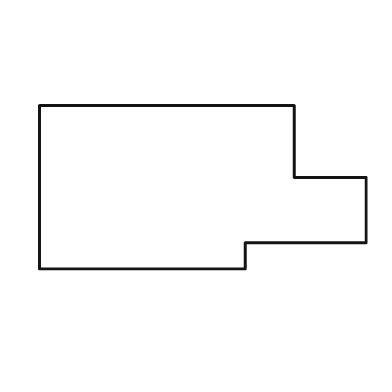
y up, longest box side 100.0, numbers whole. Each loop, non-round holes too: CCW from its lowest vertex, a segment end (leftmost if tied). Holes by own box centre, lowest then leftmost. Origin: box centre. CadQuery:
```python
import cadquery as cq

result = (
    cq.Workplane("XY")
    .moveTo(-50.0, -25.0)
    .lineTo(13.0, -25.0)
    .lineTo(13.0, -17.0)
    .lineTo(50.0, -17.0)
    .lineTo(50.0, 3.0)
    .lineTo(28.0, 3.0)
    .lineTo(28.0, 25.0)
    .lineTo(-50.0, 25.0)
    .close()
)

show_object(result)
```